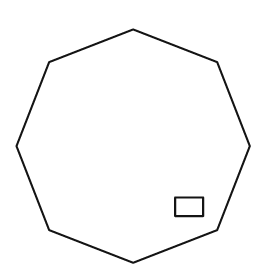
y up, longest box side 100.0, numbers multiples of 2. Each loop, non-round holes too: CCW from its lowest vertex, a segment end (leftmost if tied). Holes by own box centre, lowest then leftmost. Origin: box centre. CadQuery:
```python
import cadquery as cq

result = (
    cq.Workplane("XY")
    .moveTo(0.0, -50.0)
    .lineTo(36.0, -36.0)
    .lineTo(50.0, 0.0)
    .lineTo(36.0, 36.0)
    .lineTo(0.0, 50.0)
    .lineTo(-36.0, 36.0)
    .lineTo(-50.0, 0.0)
    .lineTo(-36.0, -36.0)
    .close()
    .moveTo(18.0, -30.0)
    .lineTo(30.0, -30.0)
    .lineTo(30.0, -22.0)
    .lineTo(18.0, -22.0)
    .close()
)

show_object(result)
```